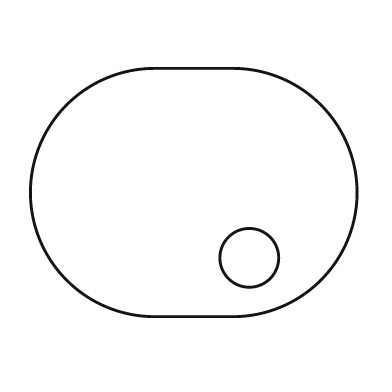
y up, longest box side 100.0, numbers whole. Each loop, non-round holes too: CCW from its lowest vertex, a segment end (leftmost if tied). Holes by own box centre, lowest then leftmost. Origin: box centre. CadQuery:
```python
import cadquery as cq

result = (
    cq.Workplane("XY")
    .moveTo(-12.0, -38.0)
    .lineTo(12.0, -38.0)
    .threePointArc((50.0, 0.0), (12.0, 38.0))
    .lineTo(-12.0, 38.0)
    .threePointArc((-50.0, 0.0), (-12.0, -38.0))
    .close()
    .moveTo(17.0, -20.0)
    .circle(9.0)
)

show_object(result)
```